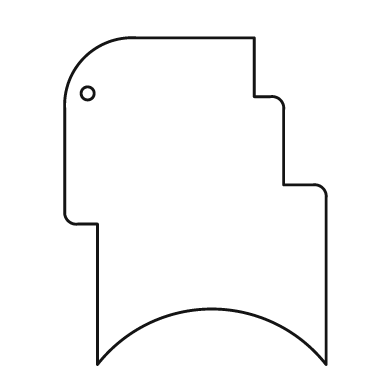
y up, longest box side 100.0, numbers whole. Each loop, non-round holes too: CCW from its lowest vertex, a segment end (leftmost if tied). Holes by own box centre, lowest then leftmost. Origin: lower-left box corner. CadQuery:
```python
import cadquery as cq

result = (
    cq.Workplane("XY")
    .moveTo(10.0, 0.0)
    .threePointArc((45.0, 17.0), (80.0, 0.0))
    .lineTo(80.0, 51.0)
    .threePointArc((79.0, 54.0), (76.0, 55.0))
    .lineTo(67.0, 55.0)
    .lineTo(67.0, 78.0)
    .threePointArc((66.0, 81.0), (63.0, 82.0))
    .lineTo(58.0, 82.0)
    .lineTo(58.0, 100.0)
    .lineTo(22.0, 100.0)
    .threePointArc((6.0, 94.0), (0.0, 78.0))
    .lineTo(0.0, 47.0)
    .threePointArc((1.0, 44.0), (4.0, 43.0))
    .lineTo(10.0, 43.0)
    .close()
    .moveTo(7.0, 83.0)
    .circle(2.0)
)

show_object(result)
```